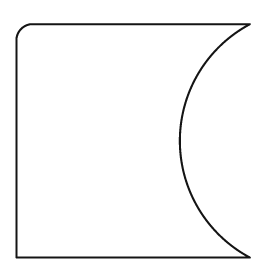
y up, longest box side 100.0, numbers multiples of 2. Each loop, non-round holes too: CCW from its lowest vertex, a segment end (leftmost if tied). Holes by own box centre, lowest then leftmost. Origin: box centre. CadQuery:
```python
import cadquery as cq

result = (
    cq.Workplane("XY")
    .moveTo(-50.0, -50.0)
    .lineTo(50.0, -50.0)
    .threePointArc((20.0, 0.0), (50.0, 50.0))
    .lineTo(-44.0, 50.0)
    .threePointArc((-48.0, 48.0), (-50.0, 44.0))
    .close()
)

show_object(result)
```